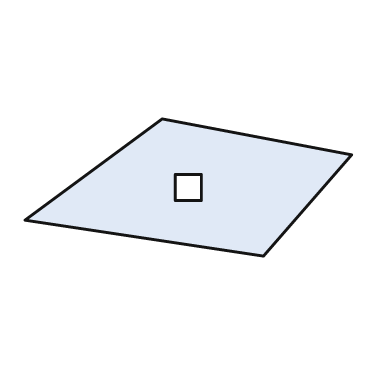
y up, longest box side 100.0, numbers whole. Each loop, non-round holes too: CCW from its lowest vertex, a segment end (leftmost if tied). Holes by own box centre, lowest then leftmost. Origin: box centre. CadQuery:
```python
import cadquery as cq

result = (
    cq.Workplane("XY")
    .moveTo(23.0, -21.0)
    .lineTo(50.0, 10.0)
    .lineTo(-8.0, 21.0)
    .lineTo(-50.0, -10.0)
    .close()
    .moveTo(-4.0, -4.0)
    .lineTo(4.0, -4.0)
    .lineTo(4.0, 4.0)
    .lineTo(-4.0, 4.0)
    .close()
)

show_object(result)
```